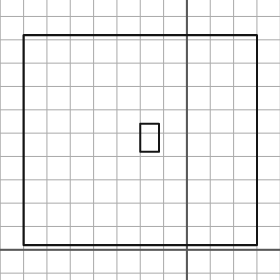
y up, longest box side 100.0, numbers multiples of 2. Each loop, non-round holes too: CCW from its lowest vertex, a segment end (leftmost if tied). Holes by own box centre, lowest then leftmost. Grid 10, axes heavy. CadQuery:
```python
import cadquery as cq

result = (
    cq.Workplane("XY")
    .moveTo(-70.0, 2.0)
    .lineTo(30.0, 2.0)
    .lineTo(30.0, 92.0)
    .lineTo(-70.0, 92.0)
    .close()
    .moveTo(-20.0, 42.0)
    .lineTo(-12.0, 42.0)
    .lineTo(-12.0, 54.0)
    .lineTo(-20.0, 54.0)
    .close()
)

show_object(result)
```